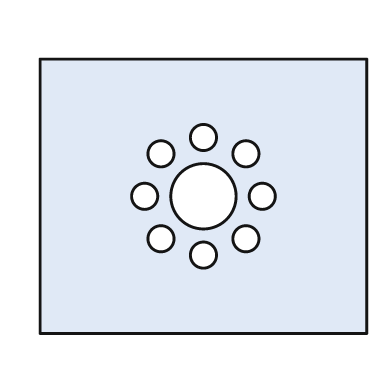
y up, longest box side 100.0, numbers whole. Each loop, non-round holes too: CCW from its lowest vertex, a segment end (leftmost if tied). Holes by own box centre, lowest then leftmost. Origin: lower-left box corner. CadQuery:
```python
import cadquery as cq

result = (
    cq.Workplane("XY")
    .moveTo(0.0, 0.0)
    .lineTo(100.0, 0.0)
    .lineTo(100.0, 84.0)
    .lineTo(0.0, 84.0)
    .close()
    .moveTo(50.0, 24.0)
    .circle(4.0)
    .moveTo(37.0, 29.0)
    .circle(4.0)
    .moveTo(63.0, 29.0)
    .circle(4.0)
    .moveTo(32.0, 42.0)
    .circle(4.0)
    .moveTo(50.0, 42.0)
    .circle(10.0)
    .moveTo(68.0, 42.0)
    .circle(4.0)
    .moveTo(37.0, 55.0)
    .circle(4.0)
    .moveTo(63.0, 55.0)
    .circle(4.0)
    .moveTo(50.0, 60.0)
    .circle(4.0)
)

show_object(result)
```